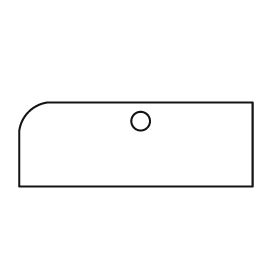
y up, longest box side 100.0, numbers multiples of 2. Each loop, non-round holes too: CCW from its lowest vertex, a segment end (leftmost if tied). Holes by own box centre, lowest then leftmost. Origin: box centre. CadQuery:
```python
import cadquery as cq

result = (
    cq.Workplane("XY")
    .moveTo(-50.0, -18.0)
    .lineTo(50.0, -18.0)
    .lineTo(50.0, 18.0)
    .lineTo(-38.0, 18.0)
    .threePointArc((-46.0, 14.0), (-50.0, 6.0))
    .close()
    .moveTo(2.0, 10.0)
    .circle(4.0)
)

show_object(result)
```